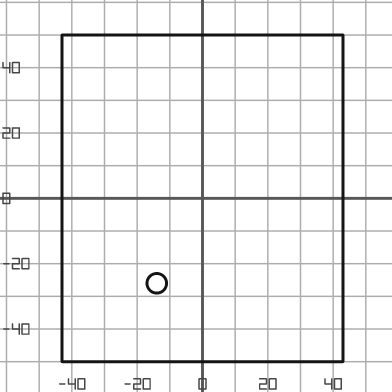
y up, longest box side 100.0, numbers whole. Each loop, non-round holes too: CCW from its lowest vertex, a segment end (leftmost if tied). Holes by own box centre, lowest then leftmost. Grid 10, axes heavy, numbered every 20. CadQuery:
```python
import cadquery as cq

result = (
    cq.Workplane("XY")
    .moveTo(-43.0, -50.0)
    .lineTo(43.0, -50.0)
    .lineTo(43.0, 50.0)
    .lineTo(-43.0, 50.0)
    .close()
    .moveTo(-14.0, -26.0)
    .circle(3.0)
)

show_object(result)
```